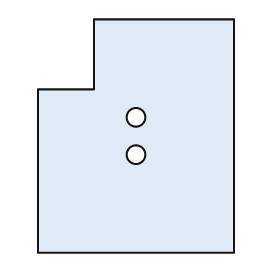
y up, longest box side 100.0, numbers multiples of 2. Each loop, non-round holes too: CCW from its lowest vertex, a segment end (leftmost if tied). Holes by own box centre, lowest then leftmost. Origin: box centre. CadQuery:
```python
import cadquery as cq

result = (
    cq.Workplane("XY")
    .moveTo(-42.0, -50.0)
    .lineTo(42.0, -50.0)
    .lineTo(42.0, 50.0)
    .lineTo(-18.0, 50.0)
    .lineTo(-18.0, 20.0)
    .lineTo(-42.0, 20.0)
    .close()
    .moveTo(0.0, -8.0)
    .circle(4.0)
    .moveTo(0.0, 8.0)
    .circle(4.0)
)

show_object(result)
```